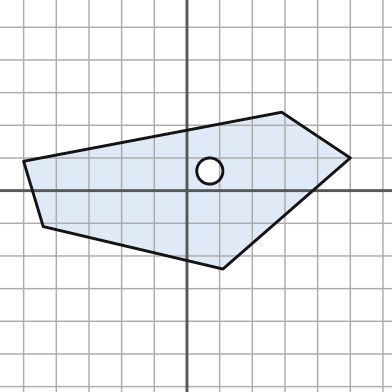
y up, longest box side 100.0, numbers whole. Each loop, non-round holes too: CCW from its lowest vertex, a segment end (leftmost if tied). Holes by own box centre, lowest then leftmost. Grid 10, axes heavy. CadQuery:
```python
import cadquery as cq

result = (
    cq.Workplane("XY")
    .moveTo(11.0, -24.0)
    .lineTo(50.0, 10.0)
    .lineTo(29.0, 24.0)
    .lineTo(-50.0, 9.0)
    .lineTo(-44.0, -11.0)
    .close()
    .moveTo(7.0, 6.0)
    .circle(4.0)
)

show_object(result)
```